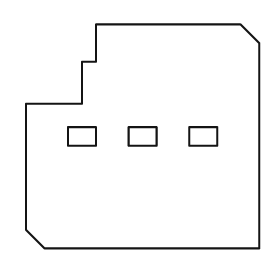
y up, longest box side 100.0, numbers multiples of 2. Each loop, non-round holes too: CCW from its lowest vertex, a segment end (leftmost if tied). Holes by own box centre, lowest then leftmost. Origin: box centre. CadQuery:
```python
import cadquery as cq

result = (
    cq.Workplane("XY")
    .moveTo(-42.0, -48.0)
    .lineTo(50.0, -48.0)
    .lineTo(50.0, 40.0)
    .lineTo(42.0, 48.0)
    .lineTo(-20.0, 48.0)
    .lineTo(-20.0, 32.0)
    .lineTo(-26.0, 32.0)
    .lineTo(-26.0, 14.0)
    .lineTo(-50.0, 14.0)
    .lineTo(-50.0, -40.0)
    .close()
    .moveTo(-32.0, -4.0)
    .lineTo(-20.0, -4.0)
    .lineTo(-20.0, 4.0)
    .lineTo(-32.0, 4.0)
    .close()
    .moveTo(-6.0, -4.0)
    .lineTo(6.0, -4.0)
    .lineTo(6.0, 4.0)
    .lineTo(-6.0, 4.0)
    .close()
    .moveTo(20.0, -4.0)
    .lineTo(32.0, -4.0)
    .lineTo(32.0, 4.0)
    .lineTo(20.0, 4.0)
    .close()
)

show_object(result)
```